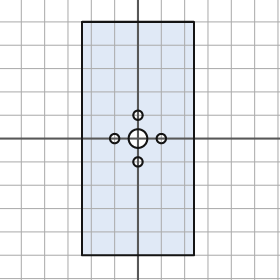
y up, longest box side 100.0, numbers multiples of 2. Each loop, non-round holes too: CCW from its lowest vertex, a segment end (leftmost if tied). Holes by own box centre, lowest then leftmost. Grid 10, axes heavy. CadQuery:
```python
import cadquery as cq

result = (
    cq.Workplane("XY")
    .moveTo(-24.0, -50.0)
    .lineTo(24.0, -50.0)
    .lineTo(24.0, 50.0)
    .lineTo(-24.0, 50.0)
    .close()
    .moveTo(0.0, -10.0)
    .circle(2.0)
    .moveTo(-10.0, 0.0)
    .circle(2.0)
    .moveTo(0.0, 0.0)
    .circle(4.0)
    .moveTo(10.0, 0.0)
    .circle(2.0)
    .moveTo(0.0, 10.0)
    .circle(2.0)
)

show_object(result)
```